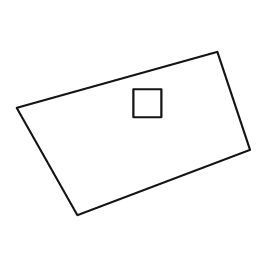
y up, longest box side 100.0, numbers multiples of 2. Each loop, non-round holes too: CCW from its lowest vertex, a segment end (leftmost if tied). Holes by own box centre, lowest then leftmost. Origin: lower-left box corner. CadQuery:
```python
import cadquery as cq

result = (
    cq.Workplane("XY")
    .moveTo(26.0, 0.0)
    .lineTo(100.0, 28.0)
    .lineTo(86.0, 70.0)
    .lineTo(0.0, 46.0)
    .close()
    .moveTo(50.0, 42.0)
    .lineTo(62.0, 42.0)
    .lineTo(62.0, 54.0)
    .lineTo(50.0, 54.0)
    .close()
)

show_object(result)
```